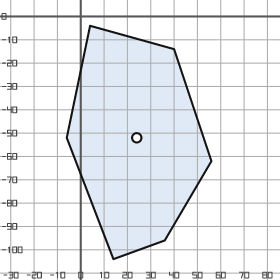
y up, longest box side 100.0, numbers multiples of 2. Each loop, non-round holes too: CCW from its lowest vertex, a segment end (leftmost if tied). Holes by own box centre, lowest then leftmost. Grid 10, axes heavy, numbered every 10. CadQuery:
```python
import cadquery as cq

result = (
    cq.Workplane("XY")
    .moveTo(14.0, -104.0)
    .lineTo(36.0, -96.0)
    .lineTo(56.0, -62.0)
    .lineTo(40.0, -14.0)
    .lineTo(4.0, -4.0)
    .lineTo(-6.0, -52.0)
    .close()
    .moveTo(24.0, -52.0)
    .circle(2.0)
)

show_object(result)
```